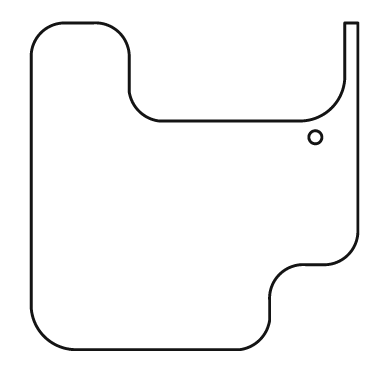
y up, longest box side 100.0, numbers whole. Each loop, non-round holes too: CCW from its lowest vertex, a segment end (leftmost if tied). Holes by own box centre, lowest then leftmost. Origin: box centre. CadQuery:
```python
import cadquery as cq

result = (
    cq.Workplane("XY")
    .moveTo(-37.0, -50.0)
    .lineTo(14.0, -50.0)
    .threePointArc((20.0, -47.0), (23.0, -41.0))
    .lineTo(23.0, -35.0)
    .threePointArc((26.0, -27.0), (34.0, -24.0))
    .lineTo(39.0, -24.0)
    .threePointArc((47.0, -21.0), (50.0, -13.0))
    .lineTo(50.0, 50.0)
    .lineTo(46.0, 50.0)
    .lineTo(46.0, 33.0)
    .threePointArc((42.0, 24.0), (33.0, 20.0))
    .lineTo(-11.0, 20.0)
    .threePointArc((-17.0, 23.0), (-20.0, 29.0))
    .lineTo(-20.0, 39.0)
    .threePointArc((-23.0, 47.0), (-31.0, 50.0))
    .lineTo(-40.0, 50.0)
    .threePointArc((-47.0, 47.0), (-50.0, 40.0))
    .lineTo(-50.0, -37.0)
    .threePointArc((-46.0, -46.0), (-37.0, -50.0))
    .close()
    .moveTo(37.0, 15.0)
    .circle(2.0)
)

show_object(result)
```